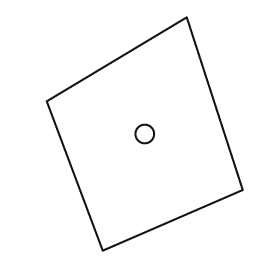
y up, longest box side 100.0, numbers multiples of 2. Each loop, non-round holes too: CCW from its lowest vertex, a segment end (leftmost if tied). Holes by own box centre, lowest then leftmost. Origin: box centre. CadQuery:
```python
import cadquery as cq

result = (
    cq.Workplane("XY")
    .moveTo(-18.0, -50.0)
    .lineTo(42.0, -24.0)
    .lineTo(18.0, 50.0)
    .lineTo(-42.0, 14.0)
    .close()
    .moveTo(0.0, 0.0)
    .circle(4.0)
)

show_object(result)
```